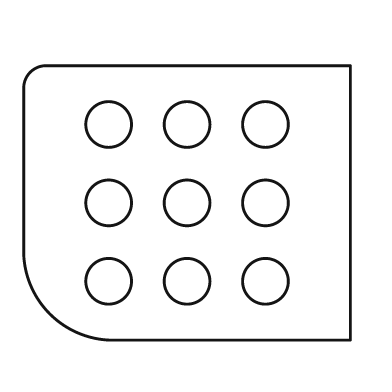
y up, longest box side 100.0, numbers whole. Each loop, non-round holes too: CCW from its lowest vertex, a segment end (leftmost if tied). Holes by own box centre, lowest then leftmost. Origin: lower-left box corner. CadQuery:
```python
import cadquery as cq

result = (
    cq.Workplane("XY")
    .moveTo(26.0, 0.0)
    .lineTo(100.0, 0.0)
    .lineTo(100.0, 84.0)
    .lineTo(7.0, 84.0)
    .threePointArc((2.0, 82.0), (0.0, 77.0))
    .lineTo(0.0, 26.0)
    .threePointArc((8.0, 8.0), (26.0, 0.0))
    .close()
    .moveTo(26.0, 18.0)
    .circle(7.0)
    .moveTo(50.0, 18.0)
    .circle(7.0)
    .moveTo(74.0, 18.0)
    .circle(7.0)
    .moveTo(26.0, 42.0)
    .circle(7.0)
    .moveTo(50.0, 42.0)
    .circle(7.0)
    .moveTo(74.0, 42.0)
    .circle(7.0)
    .moveTo(26.0, 66.0)
    .circle(7.0)
    .moveTo(50.0, 66.0)
    .circle(7.0)
    .moveTo(74.0, 66.0)
    .circle(7.0)
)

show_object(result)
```